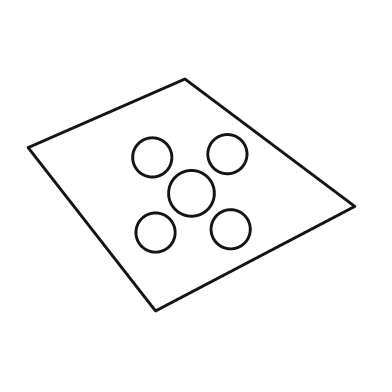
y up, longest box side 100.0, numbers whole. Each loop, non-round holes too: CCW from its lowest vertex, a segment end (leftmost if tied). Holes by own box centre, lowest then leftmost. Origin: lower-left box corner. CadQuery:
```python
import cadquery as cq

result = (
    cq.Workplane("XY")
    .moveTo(39.0, 0.0)
    .lineTo(100.0, 32.0)
    .lineTo(48.0, 71.0)
    .lineTo(0.0, 50.0)
    .close()
    .moveTo(39.0, 24.0)
    .circle(6.0)
    .moveTo(62.0, 25.0)
    .circle(6.0)
    .moveTo(50.0, 36.0)
    .circle(7.0)
    .moveTo(38.0, 47.0)
    .circle(6.0)
    .moveTo(61.0, 48.0)
    .circle(6.0)
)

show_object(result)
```